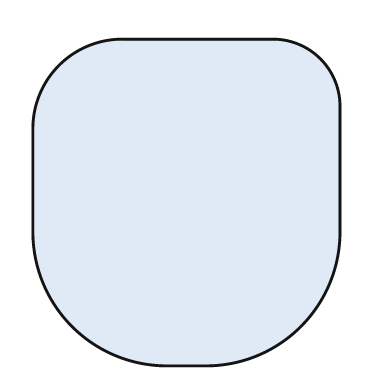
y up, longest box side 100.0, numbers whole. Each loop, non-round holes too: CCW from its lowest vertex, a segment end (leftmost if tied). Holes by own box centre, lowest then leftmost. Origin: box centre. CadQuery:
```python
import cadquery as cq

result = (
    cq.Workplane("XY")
    .moveTo(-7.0, -50.0)
    .lineTo(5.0, -50.0)
    .threePointArc((35.0, -38.0), (47.0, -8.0))
    .lineTo(47.0, 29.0)
    .threePointArc((41.0, 44.0), (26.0, 50.0))
    .lineTo(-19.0, 50.0)
    .threePointArc((-39.0, 42.0), (-47.0, 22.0))
    .lineTo(-47.0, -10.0)
    .threePointArc((-35.0, -38.0), (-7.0, -50.0))
    .close()
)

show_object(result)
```